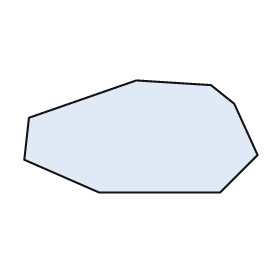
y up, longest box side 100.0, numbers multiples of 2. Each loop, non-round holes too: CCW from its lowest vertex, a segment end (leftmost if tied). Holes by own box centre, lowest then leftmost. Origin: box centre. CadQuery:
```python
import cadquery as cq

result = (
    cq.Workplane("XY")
    .moveTo(-18.0, -24.0)
    .lineTo(34.0, -24.0)
    .lineTo(50.0, -8.0)
    .lineTo(40.0, 14.0)
    .lineTo(30.0, 22.0)
    .lineTo(-2.0, 24.0)
    .lineTo(-48.0, 8.0)
    .lineTo(-50.0, -10.0)
    .close()
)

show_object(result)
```